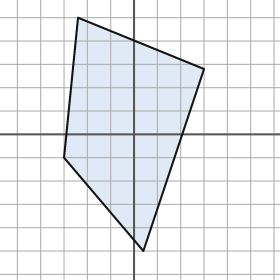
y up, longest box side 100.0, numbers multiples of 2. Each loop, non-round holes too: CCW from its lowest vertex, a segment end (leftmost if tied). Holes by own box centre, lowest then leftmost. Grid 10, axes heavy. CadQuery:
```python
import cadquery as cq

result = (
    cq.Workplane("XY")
    .moveTo(4.0, -50.0)
    .lineTo(30.0, 28.0)
    .lineTo(-24.0, 50.0)
    .lineTo(-30.0, -10.0)
    .close()
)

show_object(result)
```